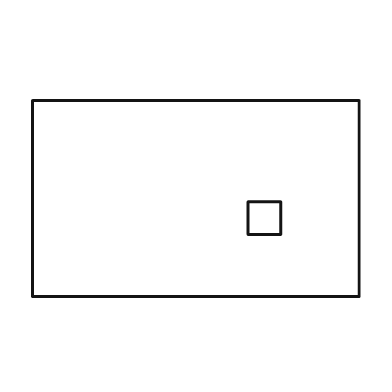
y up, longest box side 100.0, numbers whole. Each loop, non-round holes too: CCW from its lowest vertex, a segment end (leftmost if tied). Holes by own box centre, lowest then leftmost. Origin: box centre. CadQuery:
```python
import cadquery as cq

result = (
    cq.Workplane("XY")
    .moveTo(-50.0, -30.0)
    .lineTo(50.0, -30.0)
    .lineTo(50.0, 30.0)
    .lineTo(-50.0, 30.0)
    .close()
    .moveTo(16.0, -11.0)
    .lineTo(26.0, -11.0)
    .lineTo(26.0, -1.0)
    .lineTo(16.0, -1.0)
    .close()
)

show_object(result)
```